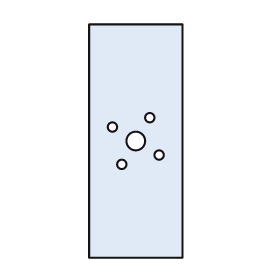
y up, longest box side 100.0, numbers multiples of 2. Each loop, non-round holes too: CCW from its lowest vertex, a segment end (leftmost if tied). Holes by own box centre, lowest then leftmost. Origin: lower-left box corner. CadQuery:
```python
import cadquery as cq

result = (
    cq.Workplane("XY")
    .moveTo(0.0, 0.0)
    .lineTo(40.0, 0.0)
    .lineTo(40.0, 100.0)
    .lineTo(0.0, 100.0)
    .close()
    .moveTo(14.0, 40.0)
    .circle(2.0)
    .moveTo(30.0, 44.0)
    .circle(2.0)
    .moveTo(20.0, 50.0)
    .circle(4.0)
    .moveTo(10.0, 56.0)
    .circle(2.0)
    .moveTo(26.0, 60.0)
    .circle(2.0)
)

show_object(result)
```